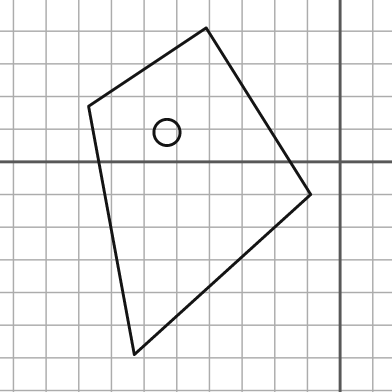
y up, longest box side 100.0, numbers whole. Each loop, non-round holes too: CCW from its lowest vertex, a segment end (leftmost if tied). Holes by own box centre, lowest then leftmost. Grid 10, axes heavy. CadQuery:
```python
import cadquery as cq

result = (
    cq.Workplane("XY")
    .moveTo(-63.0, -59.0)
    .lineTo(-9.0, -10.0)
    .lineTo(-41.0, 41.0)
    .lineTo(-77.0, 17.0)
    .close()
    .moveTo(-53.0, 9.0)
    .circle(4.0)
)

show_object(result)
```